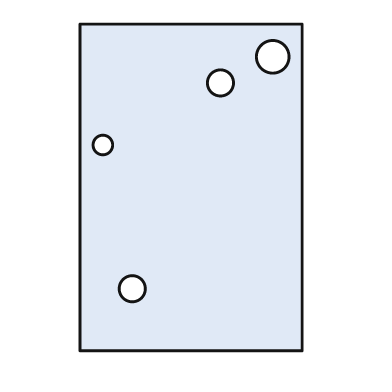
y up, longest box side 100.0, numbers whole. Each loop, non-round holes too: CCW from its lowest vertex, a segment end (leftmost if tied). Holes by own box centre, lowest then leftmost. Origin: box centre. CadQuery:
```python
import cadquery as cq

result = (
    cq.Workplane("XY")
    .moveTo(-34.0, -50.0)
    .lineTo(34.0, -50.0)
    .lineTo(34.0, 50.0)
    .lineTo(-34.0, 50.0)
    .close()
    .moveTo(-18.0, -31.0)
    .circle(4.0)
    .moveTo(-27.0, 13.0)
    .circle(3.0)
    .moveTo(9.0, 32.0)
    .circle(4.0)
    .moveTo(25.0, 40.0)
    .circle(5.0)
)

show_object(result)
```